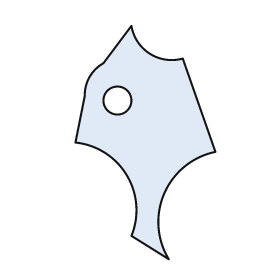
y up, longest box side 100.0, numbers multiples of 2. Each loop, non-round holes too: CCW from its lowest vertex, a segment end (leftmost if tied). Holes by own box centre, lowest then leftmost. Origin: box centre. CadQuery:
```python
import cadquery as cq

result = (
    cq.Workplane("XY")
    .moveTo(10.0, -50.0)
    .threePointArc((8.0, -22.0), (30.0, -4.0))
    .lineTo(16.0, 36.0)
    .threePointArc((2.0, 38.0), (-6.0, 50.0))
    .lineTo(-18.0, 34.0)
    .threePointArc((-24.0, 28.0), (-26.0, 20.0))
    .lineTo(-30.0, 0.0)
    .threePointArc((-8.0, -14.0), (-6.0, -40.0))
    .close()
    .moveTo(-12.0, 18.0)
    .circle(6.0)
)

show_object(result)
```